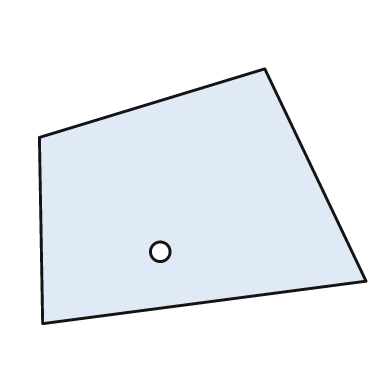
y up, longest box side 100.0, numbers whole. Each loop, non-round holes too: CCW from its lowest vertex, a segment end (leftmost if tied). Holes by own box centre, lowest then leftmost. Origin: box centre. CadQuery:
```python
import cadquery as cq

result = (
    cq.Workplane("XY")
    .moveTo(-49.0, -39.0)
    .lineTo(50.0, -26.0)
    .lineTo(19.0, 39.0)
    .lineTo(-50.0, 18.0)
    .close()
    .moveTo(-13.0, -17.0)
    .circle(3.0)
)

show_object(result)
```